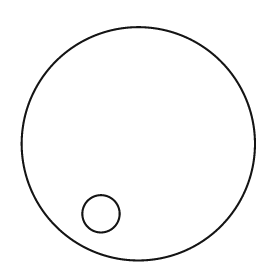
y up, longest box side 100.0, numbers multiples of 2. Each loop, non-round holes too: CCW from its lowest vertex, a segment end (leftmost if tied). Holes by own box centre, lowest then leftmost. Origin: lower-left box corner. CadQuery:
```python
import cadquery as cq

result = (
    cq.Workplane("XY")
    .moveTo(50.0, 50.0)
    .circle(50.0)
    .moveTo(34.0, 20.0)
    .circle(8.0)
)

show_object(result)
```